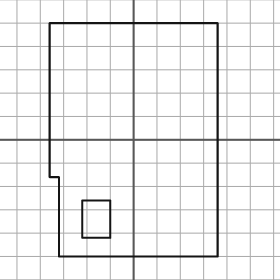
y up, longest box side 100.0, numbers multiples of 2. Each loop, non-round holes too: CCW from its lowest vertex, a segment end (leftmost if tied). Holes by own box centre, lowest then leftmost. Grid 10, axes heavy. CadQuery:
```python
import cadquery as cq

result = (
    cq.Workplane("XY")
    .moveTo(-32.0, -50.0)
    .lineTo(36.0, -50.0)
    .lineTo(36.0, 50.0)
    .lineTo(-36.0, 50.0)
    .lineTo(-36.0, -16.0)
    .lineTo(-32.0, -16.0)
    .close()
    .moveTo(-22.0, -42.0)
    .lineTo(-10.0, -42.0)
    .lineTo(-10.0, -26.0)
    .lineTo(-22.0, -26.0)
    .close()
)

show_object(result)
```